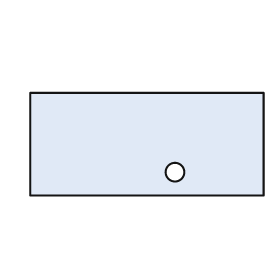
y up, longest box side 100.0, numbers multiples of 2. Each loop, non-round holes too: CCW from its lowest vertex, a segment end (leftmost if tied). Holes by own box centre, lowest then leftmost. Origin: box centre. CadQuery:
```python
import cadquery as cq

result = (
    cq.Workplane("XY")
    .moveTo(-50.0, -22.0)
    .lineTo(50.0, -22.0)
    .lineTo(50.0, 22.0)
    .lineTo(-50.0, 22.0)
    .close()
    .moveTo(12.0, -12.0)
    .circle(4.0)
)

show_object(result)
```